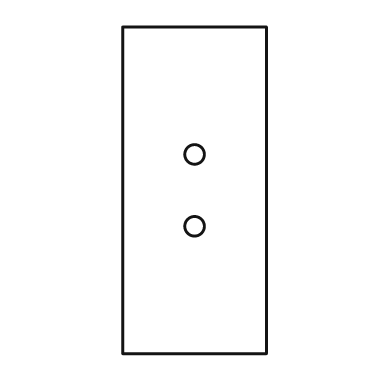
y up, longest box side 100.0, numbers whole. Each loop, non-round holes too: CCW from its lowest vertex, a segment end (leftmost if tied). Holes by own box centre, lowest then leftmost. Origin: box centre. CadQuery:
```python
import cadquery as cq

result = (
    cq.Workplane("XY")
    .moveTo(-22.0, -50.0)
    .lineTo(22.0, -50.0)
    .lineTo(22.0, 50.0)
    .lineTo(-22.0, 50.0)
    .close()
    .moveTo(0.0, -11.0)
    .circle(3.0)
    .moveTo(0.0, 11.0)
    .circle(3.0)
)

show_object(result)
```